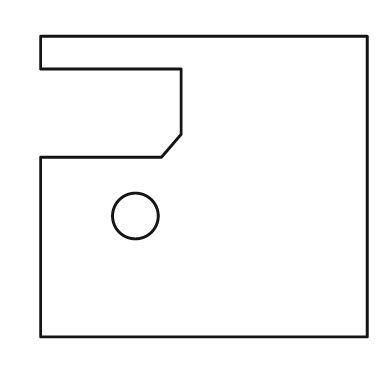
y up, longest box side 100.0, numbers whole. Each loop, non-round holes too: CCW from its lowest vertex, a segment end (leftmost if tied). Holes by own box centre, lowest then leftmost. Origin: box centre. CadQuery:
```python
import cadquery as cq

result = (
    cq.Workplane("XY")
    .moveTo(-50.0, -46.0)
    .lineTo(50.0, -46.0)
    .lineTo(50.0, 46.0)
    .lineTo(-50.0, 46.0)
    .lineTo(-50.0, 36.0)
    .lineTo(-7.0, 36.0)
    .lineTo(-7.0, 16.0)
    .lineTo(-13.0, 9.0)
    .lineTo(-50.0, 9.0)
    .close()
    .moveTo(-21.0, -9.0)
    .circle(7.0)
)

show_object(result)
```